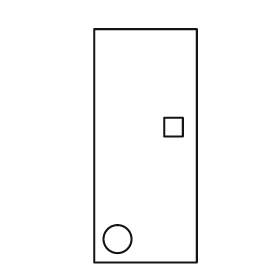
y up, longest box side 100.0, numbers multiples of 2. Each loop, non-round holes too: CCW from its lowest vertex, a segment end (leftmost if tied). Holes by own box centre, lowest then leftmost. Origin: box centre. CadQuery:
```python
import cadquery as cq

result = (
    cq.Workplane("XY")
    .moveTo(-22.0, -50.0)
    .lineTo(22.0, -50.0)
    .lineTo(22.0, 50.0)
    .lineTo(-22.0, 50.0)
    .close()
    .moveTo(-12.0, -40.0)
    .circle(6.0)
    .moveTo(8.0, 4.0)
    .lineTo(16.0, 4.0)
    .lineTo(16.0, 12.0)
    .lineTo(8.0, 12.0)
    .close()
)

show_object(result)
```